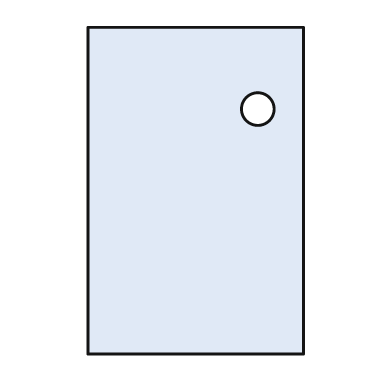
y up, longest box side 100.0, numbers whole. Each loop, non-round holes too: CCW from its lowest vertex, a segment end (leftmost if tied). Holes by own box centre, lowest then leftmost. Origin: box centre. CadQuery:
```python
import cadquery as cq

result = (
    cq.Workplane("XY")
    .moveTo(-33.0, -50.0)
    .lineTo(33.0, -50.0)
    .lineTo(33.0, 50.0)
    .lineTo(-33.0, 50.0)
    .close()
    .moveTo(19.0, 25.0)
    .circle(5.0)
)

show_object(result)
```